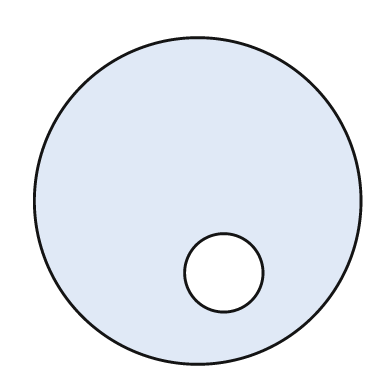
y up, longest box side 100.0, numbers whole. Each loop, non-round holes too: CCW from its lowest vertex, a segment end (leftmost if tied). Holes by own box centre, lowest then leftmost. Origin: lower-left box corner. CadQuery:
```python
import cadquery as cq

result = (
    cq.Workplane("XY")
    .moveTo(50.0, 50.0)
    .circle(50.0)
    .moveTo(58.0, 28.0)
    .circle(12.0)
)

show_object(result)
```